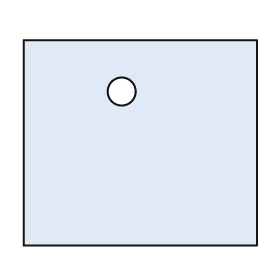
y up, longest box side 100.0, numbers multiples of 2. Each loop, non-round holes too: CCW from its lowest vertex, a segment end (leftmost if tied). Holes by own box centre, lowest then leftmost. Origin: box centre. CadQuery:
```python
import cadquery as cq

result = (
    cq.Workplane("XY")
    .moveTo(-50.0, -44.0)
    .lineTo(50.0, -44.0)
    .lineTo(50.0, 44.0)
    .lineTo(-50.0, 44.0)
    .close()
    .moveTo(-8.0, 22.0)
    .circle(6.0)
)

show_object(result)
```